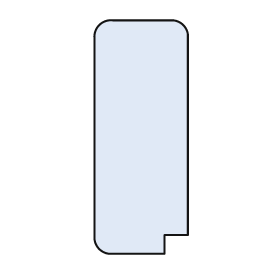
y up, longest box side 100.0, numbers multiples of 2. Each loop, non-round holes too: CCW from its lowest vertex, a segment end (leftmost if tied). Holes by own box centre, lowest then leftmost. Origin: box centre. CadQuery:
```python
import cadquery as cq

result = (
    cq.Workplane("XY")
    .moveTo(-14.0, -50.0)
    .lineTo(10.0, -50.0)
    .lineTo(10.0, -42.0)
    .lineTo(20.0, -42.0)
    .lineTo(20.0, 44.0)
    .threePointArc((18.0, 48.0), (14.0, 50.0))
    .lineTo(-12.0, 50.0)
    .threePointArc((-18.0, 48.0), (-20.0, 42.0))
    .lineTo(-20.0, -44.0)
    .threePointArc((-18.0, -48.0), (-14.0, -50.0))
    .close()
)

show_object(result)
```